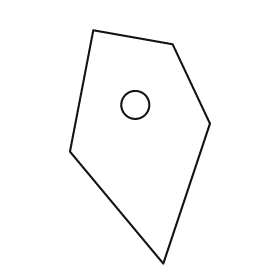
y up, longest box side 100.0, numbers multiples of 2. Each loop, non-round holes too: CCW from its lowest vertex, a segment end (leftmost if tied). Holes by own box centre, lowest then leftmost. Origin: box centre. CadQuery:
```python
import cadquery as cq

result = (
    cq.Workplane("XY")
    .moveTo(10.0, -50.0)
    .lineTo(30.0, 10.0)
    .lineTo(14.0, 44.0)
    .lineTo(-20.0, 50.0)
    .lineTo(-30.0, -2.0)
    .close()
    .moveTo(-2.0, 18.0)
    .circle(6.0)
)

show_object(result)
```